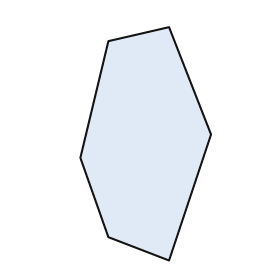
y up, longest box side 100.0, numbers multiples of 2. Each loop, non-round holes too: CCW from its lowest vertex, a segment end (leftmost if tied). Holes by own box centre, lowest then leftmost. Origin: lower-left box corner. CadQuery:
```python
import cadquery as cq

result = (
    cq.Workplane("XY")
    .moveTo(38.0, 0.0)
    .lineTo(56.0, 54.0)
    .lineTo(38.0, 100.0)
    .lineTo(12.0, 94.0)
    .lineTo(0.0, 44.0)
    .lineTo(12.0, 10.0)
    .close()
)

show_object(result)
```